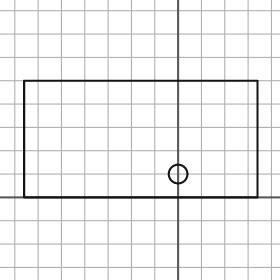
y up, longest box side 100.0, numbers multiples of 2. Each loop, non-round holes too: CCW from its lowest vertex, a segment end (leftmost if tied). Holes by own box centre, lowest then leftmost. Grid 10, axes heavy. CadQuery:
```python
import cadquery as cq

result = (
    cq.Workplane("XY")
    .moveTo(-66.0, 0.0)
    .lineTo(34.0, 0.0)
    .lineTo(34.0, 50.0)
    .lineTo(-66.0, 50.0)
    .close()
    .moveTo(0.0, 10.0)
    .circle(4.0)
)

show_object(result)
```